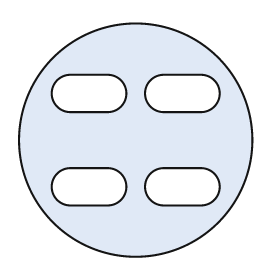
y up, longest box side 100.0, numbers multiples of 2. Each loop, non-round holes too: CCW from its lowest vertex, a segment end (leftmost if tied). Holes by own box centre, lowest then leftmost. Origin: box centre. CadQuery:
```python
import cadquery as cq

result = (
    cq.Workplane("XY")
    .moveTo(0.0, 0.0)
    .circle(50.0)
    .moveTo(-28.0, -28.0)
    .lineTo(-12.0, -28.0)
    .threePointArc((-4.0, -20.0), (-12.0, -12.0))
    .lineTo(-28.0, -12.0)
    .threePointArc((-36.0, -20.0), (-28.0, -28.0))
    .close()
    .moveTo(12.0, -28.0)
    .lineTo(28.0, -28.0)
    .threePointArc((36.0, -20.0), (28.0, -12.0))
    .lineTo(12.0, -12.0)
    .threePointArc((4.0, -20.0), (12.0, -28.0))
    .close()
    .moveTo(-28.0, 12.0)
    .lineTo(-12.0, 12.0)
    .threePointArc((-4.0, 20.0), (-12.0, 28.0))
    .lineTo(-28.0, 28.0)
    .threePointArc((-36.0, 20.0), (-28.0, 12.0))
    .close()
    .moveTo(12.0, 12.0)
    .lineTo(28.0, 12.0)
    .threePointArc((36.0, 20.0), (28.0, 28.0))
    .lineTo(12.0, 28.0)
    .threePointArc((4.0, 20.0), (12.0, 12.0))
    .close()
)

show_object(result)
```